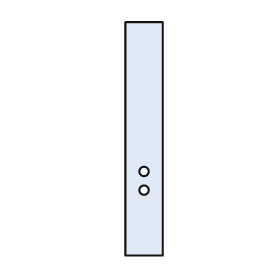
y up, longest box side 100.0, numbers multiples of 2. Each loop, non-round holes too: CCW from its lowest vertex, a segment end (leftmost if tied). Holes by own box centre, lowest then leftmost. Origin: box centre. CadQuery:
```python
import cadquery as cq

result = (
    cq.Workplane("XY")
    .moveTo(-8.0, -50.0)
    .lineTo(8.0, -50.0)
    .lineTo(8.0, 50.0)
    .lineTo(-8.0, 50.0)
    .close()
    .moveTo(0.0, -22.0)
    .circle(2.0)
    .moveTo(0.0, -14.0)
    .circle(2.0)
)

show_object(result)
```